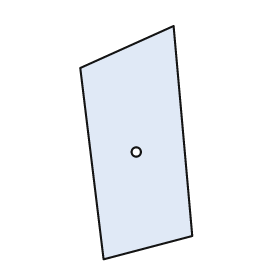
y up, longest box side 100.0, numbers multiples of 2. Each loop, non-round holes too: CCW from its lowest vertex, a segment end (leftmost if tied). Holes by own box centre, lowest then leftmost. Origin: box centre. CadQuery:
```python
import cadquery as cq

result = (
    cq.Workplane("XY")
    .moveTo(-14.0, -50.0)
    .lineTo(24.0, -40.0)
    .lineTo(16.0, 50.0)
    .lineTo(-24.0, 32.0)
    .close()
    .moveTo(0.0, -4.0)
    .circle(2.0)
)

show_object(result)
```